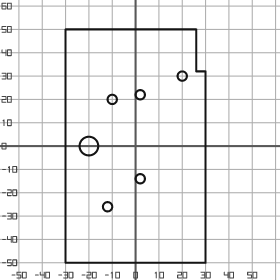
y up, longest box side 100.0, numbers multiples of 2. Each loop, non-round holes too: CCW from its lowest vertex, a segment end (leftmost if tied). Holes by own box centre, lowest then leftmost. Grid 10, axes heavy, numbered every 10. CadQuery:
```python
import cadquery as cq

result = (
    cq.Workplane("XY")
    .moveTo(-30.0, -50.0)
    .lineTo(30.0, -50.0)
    .lineTo(30.0, 32.0)
    .lineTo(26.0, 32.0)
    .lineTo(26.0, 50.0)
    .lineTo(-30.0, 50.0)
    .close()
    .moveTo(-12.0, -26.0)
    .circle(2.0)
    .moveTo(2.0, -14.0)
    .circle(2.0)
    .moveTo(-20.0, 0.0)
    .circle(4.0)
    .moveTo(-10.0, 20.0)
    .circle(2.0)
    .moveTo(2.0, 22.0)
    .circle(2.0)
    .moveTo(20.0, 30.0)
    .circle(2.0)
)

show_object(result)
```